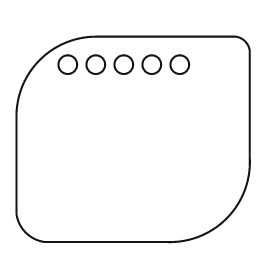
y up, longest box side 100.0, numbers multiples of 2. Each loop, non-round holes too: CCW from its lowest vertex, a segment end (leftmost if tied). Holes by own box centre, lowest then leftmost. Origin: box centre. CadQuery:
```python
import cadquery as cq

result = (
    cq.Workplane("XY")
    .moveTo(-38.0, -44.0)
    .lineTo(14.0, -44.0)
    .threePointArc((40.0, -34.0), (50.0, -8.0))
    .lineTo(50.0, 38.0)
    .threePointArc((48.0, 42.0), (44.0, 44.0))
    .lineTo(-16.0, 44.0)
    .threePointArc((-40.0, 34.0), (-50.0, 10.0))
    .lineTo(-50.0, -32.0)
    .threePointArc((-46.0, -40.0), (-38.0, -44.0))
    .close()
    .moveTo(-28.0, 32.0)
    .circle(4.0)
    .moveTo(-16.0, 32.0)
    .circle(4.0)
    .moveTo(-4.0, 32.0)
    .circle(4.0)
    .moveTo(8.0, 32.0)
    .circle(4.0)
    .moveTo(20.0, 32.0)
    .circle(4.0)
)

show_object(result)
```